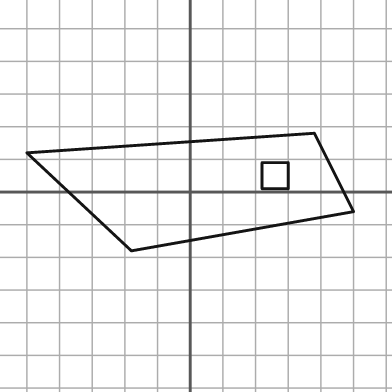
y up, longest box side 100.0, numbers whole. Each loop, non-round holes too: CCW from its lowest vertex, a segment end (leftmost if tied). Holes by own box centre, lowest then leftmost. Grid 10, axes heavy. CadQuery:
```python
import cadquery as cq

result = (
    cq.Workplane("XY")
    .moveTo(-18.0, -18.0)
    .lineTo(50.0, -6.0)
    .lineTo(38.0, 18.0)
    .lineTo(-50.0, 12.0)
    .close()
    .moveTo(22.0, 1.0)
    .lineTo(30.0, 1.0)
    .lineTo(30.0, 9.0)
    .lineTo(22.0, 9.0)
    .close()
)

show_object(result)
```